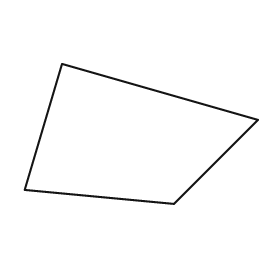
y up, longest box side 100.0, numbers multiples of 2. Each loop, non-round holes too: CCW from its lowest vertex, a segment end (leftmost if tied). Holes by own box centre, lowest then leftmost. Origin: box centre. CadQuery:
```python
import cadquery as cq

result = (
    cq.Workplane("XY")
    .moveTo(14.0, -30.0)
    .lineTo(50.0, 6.0)
    .lineTo(-34.0, 30.0)
    .lineTo(-50.0, -24.0)
    .close()
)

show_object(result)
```